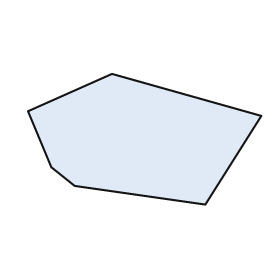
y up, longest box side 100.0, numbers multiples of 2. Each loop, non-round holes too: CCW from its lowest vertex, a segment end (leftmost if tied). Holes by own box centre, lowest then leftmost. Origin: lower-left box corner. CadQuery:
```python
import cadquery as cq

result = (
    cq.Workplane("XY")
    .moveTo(76.0, 0.0)
    .lineTo(100.0, 38.0)
    .lineTo(36.0, 56.0)
    .lineTo(0.0, 40.0)
    .lineTo(10.0, 16.0)
    .lineTo(20.0, 8.0)
    .close()
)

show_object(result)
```